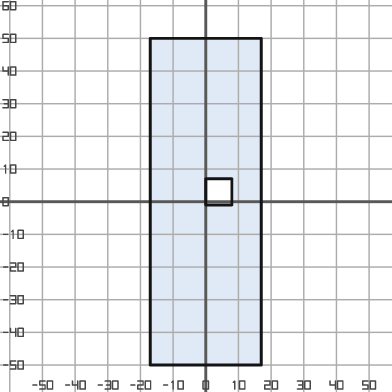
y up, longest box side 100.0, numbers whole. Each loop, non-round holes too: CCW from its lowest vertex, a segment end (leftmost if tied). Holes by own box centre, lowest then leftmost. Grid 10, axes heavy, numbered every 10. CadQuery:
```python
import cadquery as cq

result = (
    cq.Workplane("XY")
    .moveTo(-17.0, -50.0)
    .lineTo(17.0, -50.0)
    .lineTo(17.0, 50.0)
    .lineTo(-17.0, 50.0)
    .close()
    .moveTo(0.0, -1.0)
    .lineTo(8.0, -1.0)
    .lineTo(8.0, 7.0)
    .lineTo(0.0, 7.0)
    .close()
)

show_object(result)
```